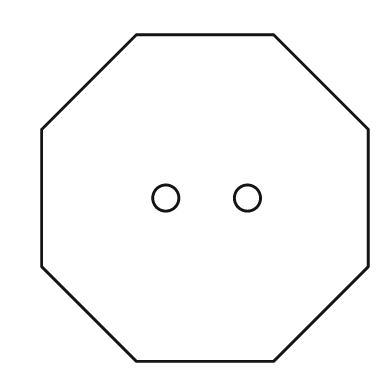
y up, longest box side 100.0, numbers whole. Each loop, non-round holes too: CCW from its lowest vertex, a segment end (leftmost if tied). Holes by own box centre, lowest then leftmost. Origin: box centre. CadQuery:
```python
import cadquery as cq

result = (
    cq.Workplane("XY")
    .moveTo(-21.0, -50.0)
    .lineTo(21.0, -50.0)
    .lineTo(50.0, -21.0)
    .lineTo(50.0, 21.0)
    .lineTo(21.0, 50.0)
    .lineTo(-21.0, 50.0)
    .lineTo(-50.0, 21.0)
    .lineTo(-50.0, -21.0)
    .close()
    .moveTo(-12.0, 0.0)
    .circle(4.0)
    .moveTo(13.0, 0.0)
    .circle(4.0)
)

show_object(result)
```